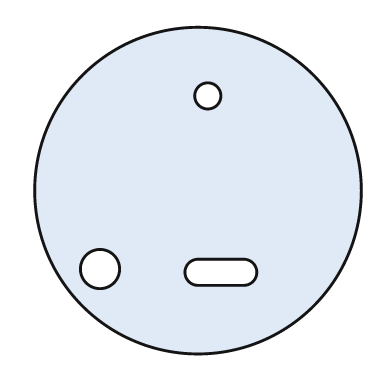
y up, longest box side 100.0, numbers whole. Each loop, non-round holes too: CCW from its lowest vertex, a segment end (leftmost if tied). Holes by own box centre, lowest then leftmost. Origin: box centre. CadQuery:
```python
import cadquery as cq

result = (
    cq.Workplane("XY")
    .moveTo(0.0, 0.0)
    .circle(50.0)
    .moveTo(0.0, -29.0)
    .lineTo(14.0, -29.0)
    .threePointArc((18.0, -25.0), (14.0, -21.0))
    .lineTo(0.0, -21.0)
    .threePointArc((-4.0, -25.0), (0.0, -29.0))
    .close()
    .moveTo(-30.0, -24.0)
    .circle(6.0)
    .moveTo(3.0, 29.0)
    .circle(4.0)
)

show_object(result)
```